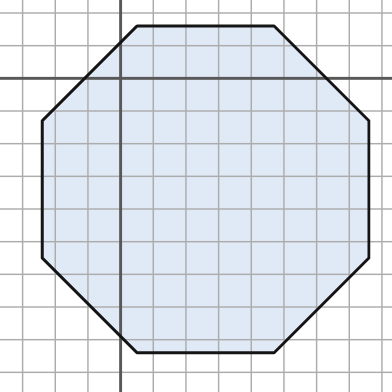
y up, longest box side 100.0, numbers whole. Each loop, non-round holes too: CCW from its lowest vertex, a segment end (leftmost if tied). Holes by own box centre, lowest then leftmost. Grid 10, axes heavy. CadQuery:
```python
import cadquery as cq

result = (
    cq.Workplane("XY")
    .moveTo(5.0, -84.0)
    .lineTo(47.0, -84.0)
    .lineTo(76.0, -55.0)
    .lineTo(76.0, -13.0)
    .lineTo(47.0, 16.0)
    .lineTo(5.0, 16.0)
    .lineTo(-24.0, -13.0)
    .lineTo(-24.0, -55.0)
    .close()
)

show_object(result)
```